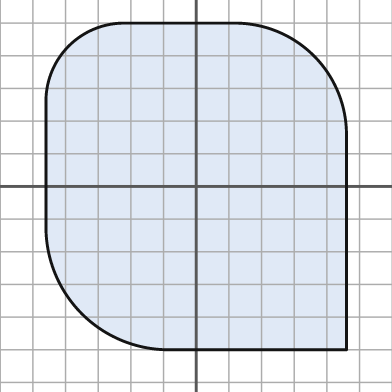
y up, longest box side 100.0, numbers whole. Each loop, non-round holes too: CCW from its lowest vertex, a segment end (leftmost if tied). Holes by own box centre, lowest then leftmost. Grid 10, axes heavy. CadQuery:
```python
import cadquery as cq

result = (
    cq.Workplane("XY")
    .moveTo(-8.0, -50.0)
    .lineTo(46.0, -50.0)
    .lineTo(46.0, 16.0)
    .threePointArc((36.0, 40.0), (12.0, 50.0))
    .lineTo(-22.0, 50.0)
    .threePointArc((-39.0, 43.0), (-46.0, 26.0))
    .lineTo(-46.0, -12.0)
    .threePointArc((-35.0, -39.0), (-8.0, -50.0))
    .close()
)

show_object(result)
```